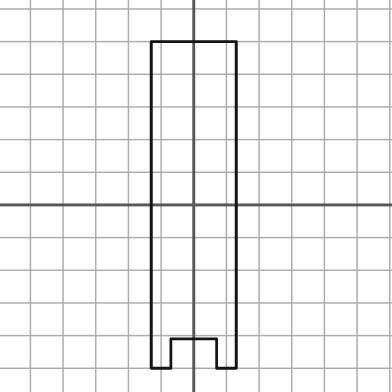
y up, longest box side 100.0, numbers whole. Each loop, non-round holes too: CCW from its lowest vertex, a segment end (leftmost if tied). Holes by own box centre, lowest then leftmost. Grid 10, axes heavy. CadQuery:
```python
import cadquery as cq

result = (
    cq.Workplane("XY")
    .moveTo(-13.0, -50.0)
    .lineTo(-7.0, -50.0)
    .lineTo(-7.0, -41.0)
    .lineTo(7.0, -41.0)
    .lineTo(7.0, -50.0)
    .lineTo(13.0, -50.0)
    .lineTo(13.0, 50.0)
    .lineTo(-13.0, 50.0)
    .close()
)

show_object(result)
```